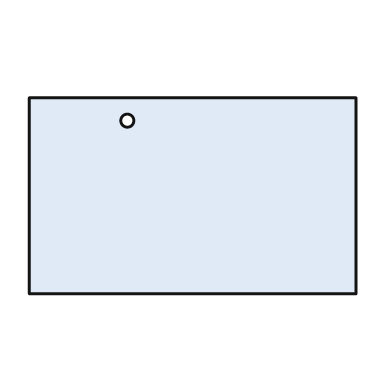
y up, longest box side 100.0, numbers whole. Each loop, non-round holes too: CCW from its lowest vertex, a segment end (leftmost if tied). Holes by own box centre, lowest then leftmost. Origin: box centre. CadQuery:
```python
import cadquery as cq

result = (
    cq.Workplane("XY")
    .moveTo(-50.0, -30.0)
    .lineTo(50.0, -30.0)
    .lineTo(50.0, 30.0)
    .lineTo(-50.0, 30.0)
    .close()
    .moveTo(-20.0, 23.0)
    .circle(2.0)
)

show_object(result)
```